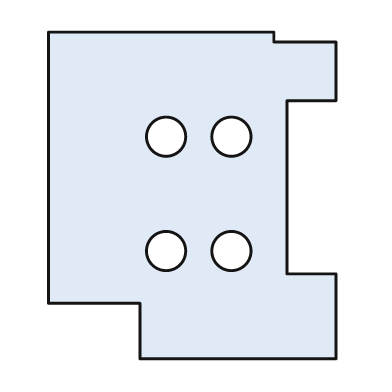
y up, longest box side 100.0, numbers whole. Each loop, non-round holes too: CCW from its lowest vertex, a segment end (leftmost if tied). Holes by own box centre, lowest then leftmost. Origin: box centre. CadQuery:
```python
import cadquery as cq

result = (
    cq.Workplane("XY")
    .moveTo(-16.0, -50.0)
    .lineTo(44.0, -50.0)
    .lineTo(44.0, -24.0)
    .lineTo(29.0, -24.0)
    .lineTo(29.0, 29.0)
    .lineTo(44.0, 29.0)
    .lineTo(44.0, 47.0)
    .lineTo(25.0, 47.0)
    .lineTo(25.0, 50.0)
    .lineTo(-44.0, 50.0)
    .lineTo(-44.0, -33.0)
    .lineTo(-16.0, -33.0)
    .close()
    .moveTo(-8.0, -17.0)
    .circle(6.0)
    .moveTo(12.0, -17.0)
    .circle(6.0)
    .moveTo(-8.0, 18.0)
    .circle(6.0)
    .moveTo(12.0, 18.0)
    .circle(6.0)
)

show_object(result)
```